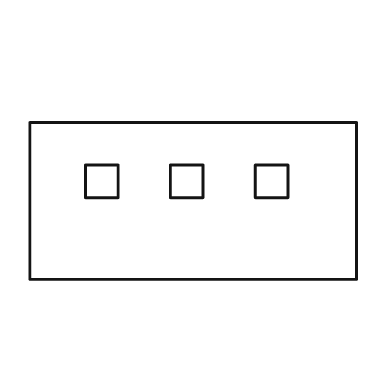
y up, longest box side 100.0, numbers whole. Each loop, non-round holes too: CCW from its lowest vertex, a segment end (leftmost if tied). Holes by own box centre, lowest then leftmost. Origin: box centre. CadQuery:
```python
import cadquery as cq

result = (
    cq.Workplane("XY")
    .moveTo(-50.0, -24.0)
    .lineTo(50.0, -24.0)
    .lineTo(50.0, 24.0)
    .lineTo(-50.0, 24.0)
    .close()
    .moveTo(-33.0, 1.0)
    .lineTo(-23.0, 1.0)
    .lineTo(-23.0, 11.0)
    .lineTo(-33.0, 11.0)
    .close()
    .moveTo(-7.0, 1.0)
    .lineTo(3.0, 1.0)
    .lineTo(3.0, 11.0)
    .lineTo(-7.0, 11.0)
    .close()
    .moveTo(19.0, 1.0)
    .lineTo(29.0, 1.0)
    .lineTo(29.0, 11.0)
    .lineTo(19.0, 11.0)
    .close()
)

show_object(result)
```